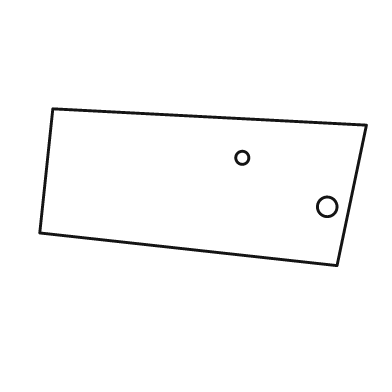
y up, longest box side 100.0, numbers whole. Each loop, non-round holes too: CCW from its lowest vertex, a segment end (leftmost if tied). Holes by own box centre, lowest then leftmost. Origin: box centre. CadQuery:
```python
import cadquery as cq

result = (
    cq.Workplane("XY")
    .moveTo(41.0, -24.0)
    .lineTo(50.0, 19.0)
    .lineTo(-46.0, 24.0)
    .lineTo(-50.0, -14.0)
    .close()
    .moveTo(38.0, -6.0)
    .circle(3.0)
    .moveTo(12.0, 9.0)
    .circle(2.0)
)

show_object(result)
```